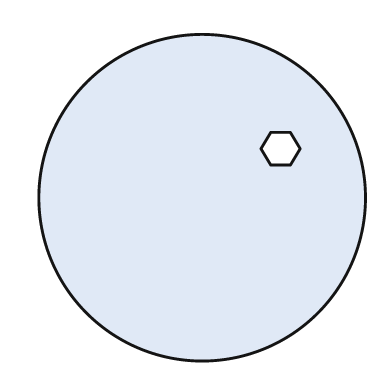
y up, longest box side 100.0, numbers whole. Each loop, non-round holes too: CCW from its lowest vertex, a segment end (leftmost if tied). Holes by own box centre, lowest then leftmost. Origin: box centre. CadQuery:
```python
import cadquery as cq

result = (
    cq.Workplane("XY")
    .moveTo(0.0, 0.0)
    .circle(50.0)
    .moveTo(21.0, 10.0)
    .lineTo(27.0, 10.0)
    .lineTo(30.0, 15.0)
    .lineTo(27.0, 20.0)
    .lineTo(21.0, 20.0)
    .lineTo(18.0, 15.0)
    .close()
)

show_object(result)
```